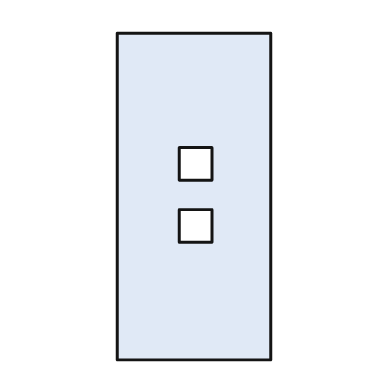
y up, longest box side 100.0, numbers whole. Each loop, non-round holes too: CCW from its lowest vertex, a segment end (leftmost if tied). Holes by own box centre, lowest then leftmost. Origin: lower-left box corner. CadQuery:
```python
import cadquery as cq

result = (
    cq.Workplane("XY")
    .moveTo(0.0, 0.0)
    .lineTo(47.0, 0.0)
    .lineTo(47.0, 100.0)
    .lineTo(0.0, 100.0)
    .close()
    .moveTo(19.0, 36.0)
    .lineTo(29.0, 36.0)
    .lineTo(29.0, 46.0)
    .lineTo(19.0, 46.0)
    .close()
    .moveTo(19.0, 55.0)
    .lineTo(29.0, 55.0)
    .lineTo(29.0, 65.0)
    .lineTo(19.0, 65.0)
    .close()
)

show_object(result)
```